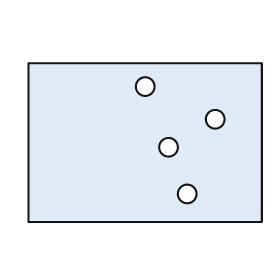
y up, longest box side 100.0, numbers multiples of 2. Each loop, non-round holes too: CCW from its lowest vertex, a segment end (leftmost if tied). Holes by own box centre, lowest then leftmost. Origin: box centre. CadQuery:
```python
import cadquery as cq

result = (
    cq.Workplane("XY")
    .moveTo(-50.0, -34.0)
    .lineTo(50.0, -34.0)
    .lineTo(50.0, 34.0)
    .lineTo(-50.0, 34.0)
    .close()
    .moveTo(18.0, -22.0)
    .circle(4.0)
    .moveTo(10.0, -2.0)
    .circle(4.0)
    .moveTo(30.0, 10.0)
    .circle(4.0)
    .moveTo(0.0, 24.0)
    .circle(4.0)
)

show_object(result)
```